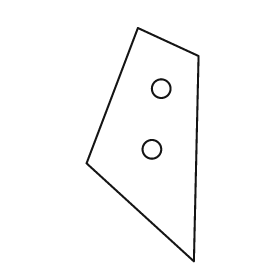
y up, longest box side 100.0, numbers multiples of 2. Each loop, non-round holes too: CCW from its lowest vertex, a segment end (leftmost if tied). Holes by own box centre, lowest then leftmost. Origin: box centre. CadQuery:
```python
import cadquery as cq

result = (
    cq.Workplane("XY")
    .moveTo(22.0, -50.0)
    .lineTo(24.0, 38.0)
    .lineTo(-2.0, 50.0)
    .lineTo(-24.0, -8.0)
    .close()
    .moveTo(4.0, -2.0)
    .circle(4.0)
    .moveTo(8.0, 24.0)
    .circle(4.0)
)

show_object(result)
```